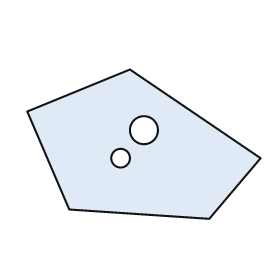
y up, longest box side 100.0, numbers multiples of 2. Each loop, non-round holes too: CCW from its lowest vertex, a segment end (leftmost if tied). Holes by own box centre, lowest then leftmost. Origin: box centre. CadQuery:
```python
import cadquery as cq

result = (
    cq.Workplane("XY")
    .moveTo(28.0, -32.0)
    .lineTo(50.0, -6.0)
    .lineTo(-6.0, 32.0)
    .lineTo(-50.0, 14.0)
    .lineTo(-32.0, -28.0)
    .close()
    .moveTo(-10.0, -6.0)
    .circle(4.0)
    .moveTo(0.0, 6.0)
    .circle(6.0)
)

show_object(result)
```